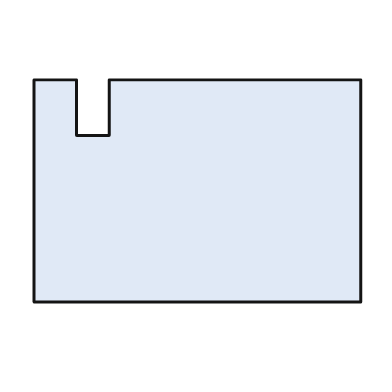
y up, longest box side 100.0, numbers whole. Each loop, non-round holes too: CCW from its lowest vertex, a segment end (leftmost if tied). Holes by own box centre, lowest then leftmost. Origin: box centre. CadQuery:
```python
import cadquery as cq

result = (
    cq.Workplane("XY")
    .moveTo(-50.0, -34.0)
    .lineTo(50.0, -34.0)
    .lineTo(50.0, 34.0)
    .lineTo(-27.0, 34.0)
    .lineTo(-27.0, 17.0)
    .lineTo(-37.0, 17.0)
    .lineTo(-37.0, 34.0)
    .lineTo(-50.0, 34.0)
    .close()
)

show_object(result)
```